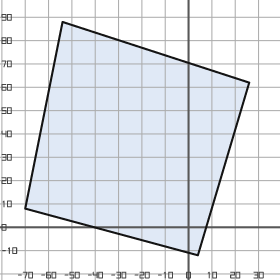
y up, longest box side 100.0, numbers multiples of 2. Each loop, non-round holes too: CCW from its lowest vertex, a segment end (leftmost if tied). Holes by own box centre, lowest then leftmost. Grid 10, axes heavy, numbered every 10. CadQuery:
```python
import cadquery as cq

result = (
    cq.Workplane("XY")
    .moveTo(4.0, -12.0)
    .lineTo(26.0, 62.0)
    .lineTo(-54.0, 88.0)
    .lineTo(-70.0, 8.0)
    .close()
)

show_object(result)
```